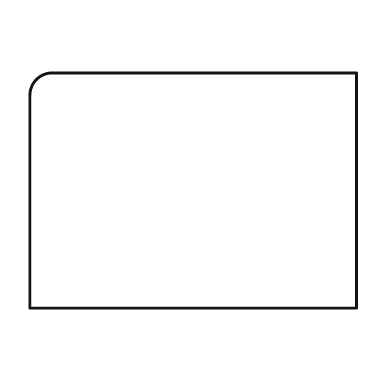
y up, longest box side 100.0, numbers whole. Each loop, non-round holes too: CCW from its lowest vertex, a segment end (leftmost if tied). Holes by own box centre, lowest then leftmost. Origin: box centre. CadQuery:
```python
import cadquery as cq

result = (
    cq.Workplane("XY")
    .moveTo(-50.0, -36.0)
    .lineTo(50.0, -36.0)
    .lineTo(50.0, 36.0)
    .lineTo(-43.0, 36.0)
    .threePointArc((-48.0, 34.0), (-50.0, 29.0))
    .close()
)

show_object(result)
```